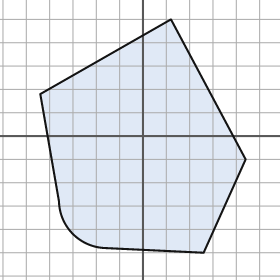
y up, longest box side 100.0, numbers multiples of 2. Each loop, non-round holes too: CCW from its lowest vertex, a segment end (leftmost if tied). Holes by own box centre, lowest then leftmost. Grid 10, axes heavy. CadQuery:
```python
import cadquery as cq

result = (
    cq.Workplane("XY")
    .moveTo(26.0, -50.0)
    .lineTo(44.0, -10.0)
    .lineTo(12.0, 50.0)
    .lineTo(-44.0, 18.0)
    .lineTo(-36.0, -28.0)
    .threePointArc((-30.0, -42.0), (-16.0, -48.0))
    .close()
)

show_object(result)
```